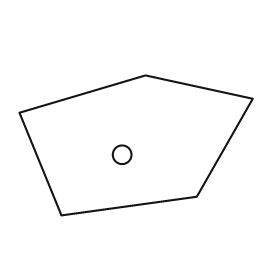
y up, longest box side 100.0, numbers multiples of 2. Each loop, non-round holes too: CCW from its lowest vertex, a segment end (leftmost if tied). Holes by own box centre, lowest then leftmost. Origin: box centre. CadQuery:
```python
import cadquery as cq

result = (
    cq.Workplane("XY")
    .moveTo(-32.0, -30.0)
    .lineTo(26.0, -22.0)
    .lineTo(50.0, 20.0)
    .lineTo(4.0, 30.0)
    .lineTo(-50.0, 14.0)
    .close()
    .moveTo(-6.0, -4.0)
    .circle(4.0)
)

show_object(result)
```